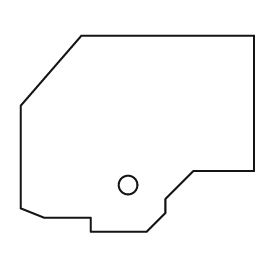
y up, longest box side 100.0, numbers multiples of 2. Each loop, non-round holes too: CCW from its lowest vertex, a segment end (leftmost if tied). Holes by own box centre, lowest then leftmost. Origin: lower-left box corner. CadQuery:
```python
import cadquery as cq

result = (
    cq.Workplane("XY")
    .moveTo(30.0, 0.0)
    .lineTo(54.0, 0.0)
    .lineTo(62.0, 8.0)
    .lineTo(62.0, 14.0)
    .lineTo(74.0, 26.0)
    .lineTo(100.0, 26.0)
    .lineTo(100.0, 84.0)
    .lineTo(26.0, 84.0)
    .lineTo(0.0, 54.0)
    .lineTo(0.0, 10.0)
    .lineTo(10.0, 6.0)
    .lineTo(30.0, 6.0)
    .close()
    .moveTo(46.0, 20.0)
    .circle(4.0)
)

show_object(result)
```